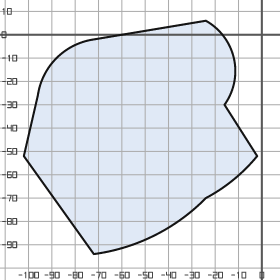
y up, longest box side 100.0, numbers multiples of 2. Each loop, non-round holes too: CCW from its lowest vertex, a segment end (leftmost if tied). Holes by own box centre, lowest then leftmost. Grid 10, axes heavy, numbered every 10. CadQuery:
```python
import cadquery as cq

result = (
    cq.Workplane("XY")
    .moveTo(-72.0, -94.0)
    .threePointArc((-46.0, -86.0), (-24.0, -70.0))
    .threePointArc((-12.0, -62.0), (-2.0, -52.0))
    .lineTo(-16.0, -30.0)
    .threePointArc((-12.0, -10.0), (-24.0, 6.0))
    .lineTo(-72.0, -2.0)
    .threePointArc((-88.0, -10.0), (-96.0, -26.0))
    .lineTo(-102.0, -52.0)
    .close()
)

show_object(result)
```